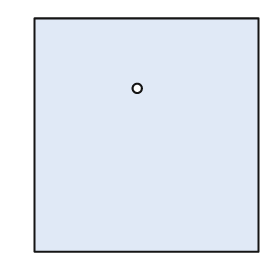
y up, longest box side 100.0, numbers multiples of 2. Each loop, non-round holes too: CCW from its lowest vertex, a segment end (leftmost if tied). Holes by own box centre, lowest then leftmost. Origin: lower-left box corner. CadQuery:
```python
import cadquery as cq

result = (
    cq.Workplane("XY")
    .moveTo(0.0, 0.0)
    .lineTo(96.0, 0.0)
    .lineTo(96.0, 100.0)
    .lineTo(0.0, 100.0)
    .close()
    .moveTo(44.0, 70.0)
    .circle(2.0)
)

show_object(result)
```